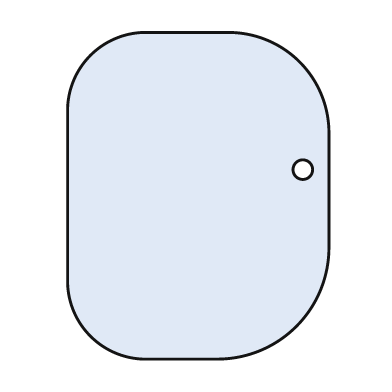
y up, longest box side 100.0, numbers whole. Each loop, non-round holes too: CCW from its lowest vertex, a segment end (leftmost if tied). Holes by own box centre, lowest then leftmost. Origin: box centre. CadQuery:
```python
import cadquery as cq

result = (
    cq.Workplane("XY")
    .moveTo(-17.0, -50.0)
    .lineTo(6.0, -50.0)
    .threePointArc((30.0, -40.0), (40.0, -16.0))
    .lineTo(40.0, 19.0)
    .threePointArc((31.0, 41.0), (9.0, 50.0))
    .lineTo(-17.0, 50.0)
    .threePointArc((-33.0, 43.0), (-40.0, 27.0))
    .lineTo(-40.0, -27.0)
    .threePointArc((-33.0, -43.0), (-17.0, -50.0))
    .close()
    .moveTo(32.0, 8.0)
    .circle(3.0)
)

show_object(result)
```